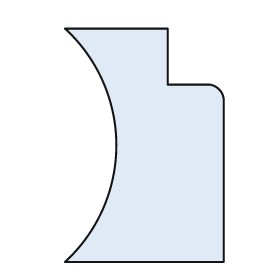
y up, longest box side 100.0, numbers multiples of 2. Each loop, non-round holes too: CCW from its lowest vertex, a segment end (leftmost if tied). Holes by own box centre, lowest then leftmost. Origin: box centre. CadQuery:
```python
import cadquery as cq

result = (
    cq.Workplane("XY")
    .moveTo(-34.0, -50.0)
    .lineTo(34.0, -50.0)
    .lineTo(34.0, 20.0)
    .threePointArc((32.0, 24.0), (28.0, 26.0))
    .lineTo(10.0, 26.0)
    .lineTo(10.0, 50.0)
    .lineTo(-34.0, 50.0)
    .threePointArc((-12.0, 0.0), (-34.0, -50.0))
    .close()
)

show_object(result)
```